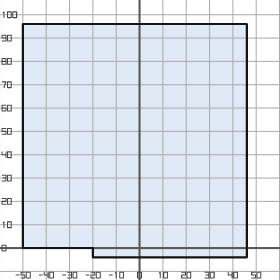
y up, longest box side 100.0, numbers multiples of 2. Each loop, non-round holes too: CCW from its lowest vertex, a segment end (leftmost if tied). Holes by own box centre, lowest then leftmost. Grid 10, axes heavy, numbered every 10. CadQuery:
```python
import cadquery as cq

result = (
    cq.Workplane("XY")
    .moveTo(-20.0, -4.0)
    .lineTo(46.0, -4.0)
    .lineTo(46.0, 96.0)
    .lineTo(-50.0, 96.0)
    .lineTo(-50.0, 0.0)
    .lineTo(-20.0, 0.0)
    .close()
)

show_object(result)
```